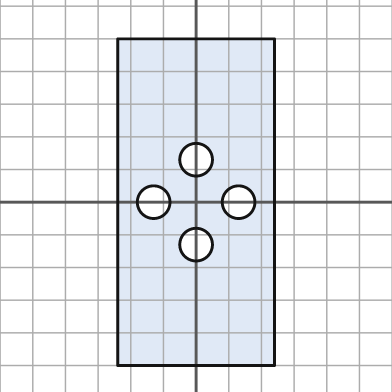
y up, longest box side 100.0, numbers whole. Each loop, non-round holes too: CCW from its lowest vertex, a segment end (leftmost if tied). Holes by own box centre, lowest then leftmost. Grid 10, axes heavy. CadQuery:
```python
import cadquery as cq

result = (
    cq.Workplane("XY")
    .moveTo(-24.0, -50.0)
    .lineTo(24.0, -50.0)
    .lineTo(24.0, 50.0)
    .lineTo(-24.0, 50.0)
    .close()
    .moveTo(0.0, -13.0)
    .circle(5.0)
    .moveTo(-13.0, 0.0)
    .circle(5.0)
    .moveTo(13.0, 0.0)
    .circle(5.0)
    .moveTo(0.0, 13.0)
    .circle(5.0)
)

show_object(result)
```